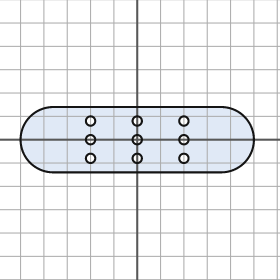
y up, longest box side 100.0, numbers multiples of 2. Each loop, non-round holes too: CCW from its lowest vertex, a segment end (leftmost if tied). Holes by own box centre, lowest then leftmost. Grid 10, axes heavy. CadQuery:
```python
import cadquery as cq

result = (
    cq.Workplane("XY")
    .moveTo(-36.0, -14.0)
    .lineTo(36.0, -14.0)
    .threePointArc((50.0, 0.0), (36.0, 14.0))
    .lineTo(-36.0, 14.0)
    .threePointArc((-50.0, 0.0), (-36.0, -14.0))
    .close()
    .moveTo(-20.0, -8.0)
    .circle(2.0)
    .moveTo(0.0, -8.0)
    .circle(2.0)
    .moveTo(20.0, -8.0)
    .circle(2.0)
    .moveTo(-20.0, 0.0)
    .circle(2.0)
    .moveTo(0.0, 0.0)
    .circle(2.0)
    .moveTo(20.0, 0.0)
    .circle(2.0)
    .moveTo(-20.0, 8.0)
    .circle(2.0)
    .moveTo(0.0, 8.0)
    .circle(2.0)
    .moveTo(20.0, 8.0)
    .circle(2.0)
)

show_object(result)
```